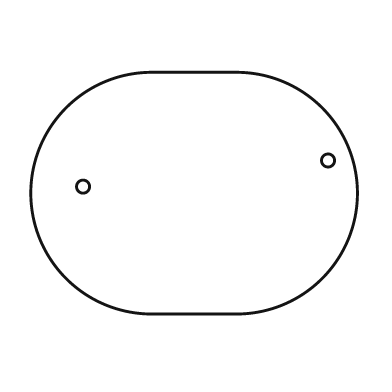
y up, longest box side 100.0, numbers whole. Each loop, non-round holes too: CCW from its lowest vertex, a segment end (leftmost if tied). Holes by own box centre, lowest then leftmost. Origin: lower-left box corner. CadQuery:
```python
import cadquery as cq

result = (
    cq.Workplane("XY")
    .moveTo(37.0, 0.0)
    .lineTo(63.0, 0.0)
    .threePointArc((100.0, 37.0), (63.0, 74.0))
    .lineTo(37.0, 74.0)
    .threePointArc((0.0, 37.0), (37.0, 0.0))
    .close()
    .moveTo(16.0, 39.0)
    .circle(2.0)
    .moveTo(91.0, 47.0)
    .circle(2.0)
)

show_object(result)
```